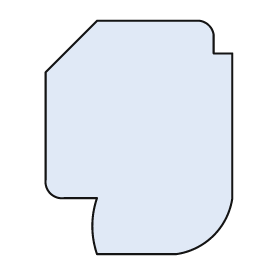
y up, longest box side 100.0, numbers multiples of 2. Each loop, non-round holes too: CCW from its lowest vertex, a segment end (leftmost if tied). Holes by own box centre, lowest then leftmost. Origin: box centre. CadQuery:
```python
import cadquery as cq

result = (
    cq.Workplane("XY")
    .moveTo(-18.0, -50.0)
    .lineTo(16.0, -50.0)
    .threePointArc((32.0, -42.0), (40.0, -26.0))
    .lineTo(40.0, 36.0)
    .lineTo(32.0, 36.0)
    .lineTo(32.0, 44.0)
    .threePointArc((30.0, 48.0), (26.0, 50.0))
    .lineTo(-18.0, 50.0)
    .lineTo(-40.0, 28.0)
    .lineTo(-40.0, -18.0)
    .threePointArc((-38.0, -24.0), (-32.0, -26.0))
    .lineTo(-18.0, -26.0)
    .threePointArc((-20.0, -38.0), (-18.0, -50.0))
    .close()
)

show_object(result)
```